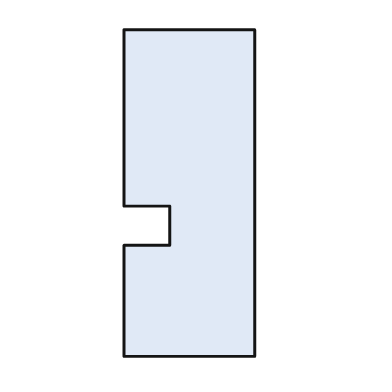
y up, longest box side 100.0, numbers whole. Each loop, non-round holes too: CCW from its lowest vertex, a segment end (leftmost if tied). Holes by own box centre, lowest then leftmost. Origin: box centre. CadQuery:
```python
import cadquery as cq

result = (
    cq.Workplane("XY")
    .moveTo(-20.0, -50.0)
    .lineTo(20.0, -50.0)
    .lineTo(20.0, 50.0)
    .lineTo(-20.0, 50.0)
    .lineTo(-20.0, -4.0)
    .lineTo(-6.0, -4.0)
    .lineTo(-6.0, -16.0)
    .lineTo(-20.0, -16.0)
    .close()
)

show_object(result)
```